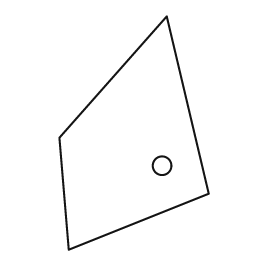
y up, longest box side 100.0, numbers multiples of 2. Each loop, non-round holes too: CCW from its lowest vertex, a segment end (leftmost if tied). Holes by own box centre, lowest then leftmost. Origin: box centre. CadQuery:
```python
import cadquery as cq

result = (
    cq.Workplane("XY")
    .moveTo(-28.0, -50.0)
    .lineTo(32.0, -26.0)
    .lineTo(14.0, 50.0)
    .lineTo(-32.0, -2.0)
    .close()
    .moveTo(12.0, -14.0)
    .circle(4.0)
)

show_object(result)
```